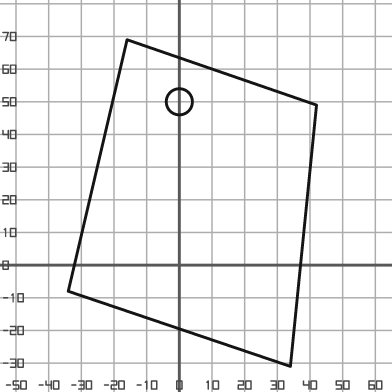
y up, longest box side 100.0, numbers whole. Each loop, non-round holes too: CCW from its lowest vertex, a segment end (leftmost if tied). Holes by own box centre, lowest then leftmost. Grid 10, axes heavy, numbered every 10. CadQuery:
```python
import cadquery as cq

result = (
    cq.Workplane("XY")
    .moveTo(34.0, -31.0)
    .lineTo(42.0, 49.0)
    .lineTo(-16.0, 69.0)
    .lineTo(-34.0, -8.0)
    .close()
    .moveTo(0.0, 50.0)
    .circle(4.0)
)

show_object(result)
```